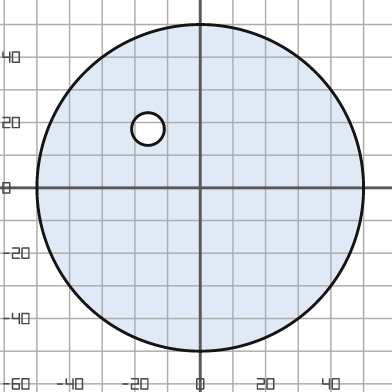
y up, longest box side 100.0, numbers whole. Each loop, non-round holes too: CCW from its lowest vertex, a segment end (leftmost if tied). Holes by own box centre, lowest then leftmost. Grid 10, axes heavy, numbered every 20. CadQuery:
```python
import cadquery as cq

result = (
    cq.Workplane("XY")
    .moveTo(0.0, 0.0)
    .circle(50.0)
    .moveTo(-16.0, 18.0)
    .circle(5.0)
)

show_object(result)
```